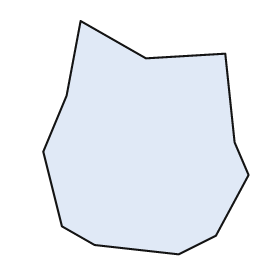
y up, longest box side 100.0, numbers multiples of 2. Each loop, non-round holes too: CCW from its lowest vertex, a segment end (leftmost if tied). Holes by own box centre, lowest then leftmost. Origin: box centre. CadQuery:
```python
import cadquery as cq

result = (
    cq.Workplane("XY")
    .moveTo(14.0, -50.0)
    .lineTo(30.0, -42.0)
    .lineTo(44.0, -16.0)
    .lineTo(38.0, -2.0)
    .lineTo(34.0, 36.0)
    .lineTo(0.0, 34.0)
    .lineTo(-28.0, 50.0)
    .lineTo(-34.0, 18.0)
    .lineTo(-44.0, -6.0)
    .lineTo(-36.0, -38.0)
    .lineTo(-22.0, -46.0)
    .close()
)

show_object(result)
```